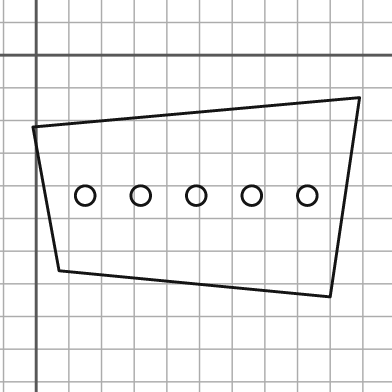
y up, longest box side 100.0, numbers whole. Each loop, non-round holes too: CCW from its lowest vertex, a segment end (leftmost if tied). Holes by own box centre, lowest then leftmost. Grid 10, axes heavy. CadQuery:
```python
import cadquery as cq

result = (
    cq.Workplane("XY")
    .moveTo(90.0, -74.0)
    .lineTo(99.0, -13.0)
    .lineTo(-1.0, -22.0)
    .lineTo(7.0, -66.0)
    .close()
    .moveTo(15.0, -43.0)
    .circle(3.0)
    .moveTo(32.0, -43.0)
    .circle(3.0)
    .moveTo(49.0, -43.0)
    .circle(3.0)
    .moveTo(66.0, -43.0)
    .circle(3.0)
    .moveTo(83.0, -43.0)
    .circle(3.0)
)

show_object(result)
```